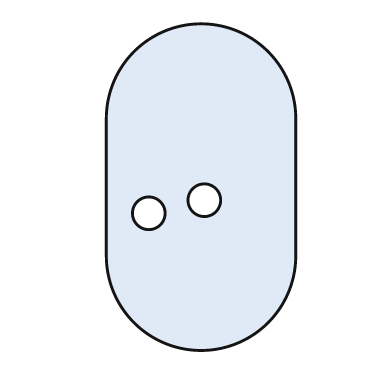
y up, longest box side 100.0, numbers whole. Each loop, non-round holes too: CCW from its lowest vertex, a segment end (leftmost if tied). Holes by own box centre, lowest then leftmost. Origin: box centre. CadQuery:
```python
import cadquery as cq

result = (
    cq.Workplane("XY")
    .moveTo(-29.0, -21.0)
    .threePointArc((0.0, -50.0), (29.0, -21.0))
    .lineTo(29.0, 21.0)
    .threePointArc((0.0, 50.0), (-29.0, 21.0))
    .close()
    .moveTo(-16.0, -8.0)
    .circle(5.0)
    .moveTo(1.0, -4.0)
    .circle(5.0)
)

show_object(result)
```